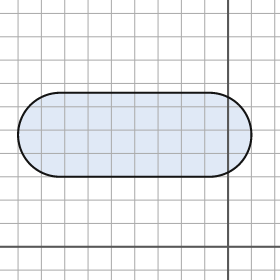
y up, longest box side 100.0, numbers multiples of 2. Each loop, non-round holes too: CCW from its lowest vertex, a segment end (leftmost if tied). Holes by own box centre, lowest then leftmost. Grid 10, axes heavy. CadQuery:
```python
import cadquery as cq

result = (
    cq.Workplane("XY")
    .moveTo(-72.0, 30.0)
    .lineTo(-8.0, 30.0)
    .threePointArc((10.0, 48.0), (-8.0, 66.0))
    .lineTo(-72.0, 66.0)
    .threePointArc((-90.0, 48.0), (-72.0, 30.0))
    .close()
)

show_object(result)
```